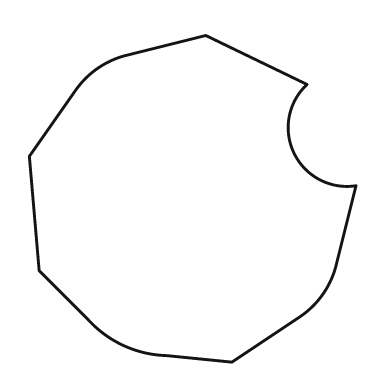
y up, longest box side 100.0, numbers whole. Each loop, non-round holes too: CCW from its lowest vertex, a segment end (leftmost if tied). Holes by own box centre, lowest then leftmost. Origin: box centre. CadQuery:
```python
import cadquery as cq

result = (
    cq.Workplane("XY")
    .moveTo(12.0, -50.0)
    .lineTo(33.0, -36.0)
    .threePointArc((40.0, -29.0), (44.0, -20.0))
    .lineTo(50.0, 4.0)
    .threePointArc((31.0, 14.0), (35.0, 35.0))
    .lineTo(4.0, 50.0)
    .lineTo(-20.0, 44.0)
    .threePointArc((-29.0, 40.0), (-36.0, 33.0))
    .lineTo(-50.0, 13.0)
    .lineTo(-47.0, -22.0)
    .lineTo(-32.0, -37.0)
    .threePointArc((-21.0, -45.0), (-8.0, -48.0))
    .close()
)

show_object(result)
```